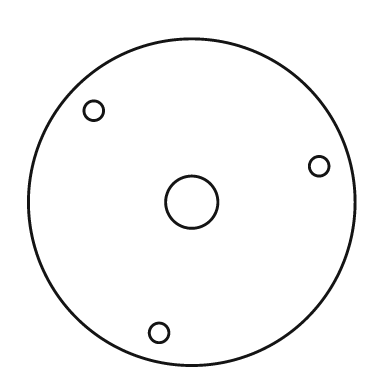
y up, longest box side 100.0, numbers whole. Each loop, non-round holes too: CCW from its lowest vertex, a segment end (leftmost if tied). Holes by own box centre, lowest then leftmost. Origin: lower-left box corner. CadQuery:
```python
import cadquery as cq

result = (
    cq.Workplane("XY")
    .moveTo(50.0, 50.0)
    .circle(50.0)
    .moveTo(40.0, 10.0)
    .circle(3.0)
    .moveTo(50.0, 50.0)
    .circle(8.0)
    .moveTo(89.0, 61.0)
    .circle(3.0)
    .moveTo(20.0, 78.0)
    .circle(3.0)
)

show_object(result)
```